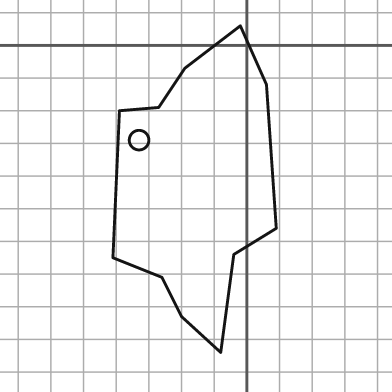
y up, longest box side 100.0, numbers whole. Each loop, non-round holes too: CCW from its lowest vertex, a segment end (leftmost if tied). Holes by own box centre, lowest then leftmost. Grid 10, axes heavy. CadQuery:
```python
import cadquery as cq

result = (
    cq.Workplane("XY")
    .moveTo(-8.0, -94.0)
    .lineTo(-4.0, -64.0)
    .lineTo(9.0, -56.0)
    .lineTo(6.0, -12.0)
    .lineTo(-2.0, 6.0)
    .lineTo(-19.0, -7.0)
    .lineTo(-27.0, -19.0)
    .lineTo(-39.0, -20.0)
    .lineTo(-41.0, -65.0)
    .lineTo(-26.0, -71.0)
    .lineTo(-20.0, -83.0)
    .close()
    .moveTo(-33.0, -29.0)
    .circle(3.0)
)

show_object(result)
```